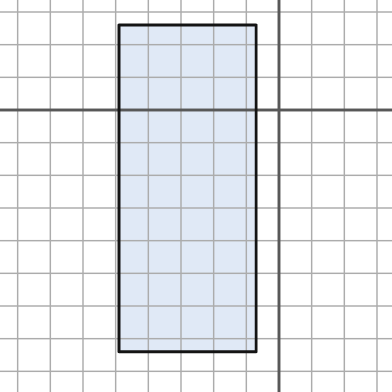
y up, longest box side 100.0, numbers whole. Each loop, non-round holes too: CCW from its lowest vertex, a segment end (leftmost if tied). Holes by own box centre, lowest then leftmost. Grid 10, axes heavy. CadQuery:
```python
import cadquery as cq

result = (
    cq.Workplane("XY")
    .moveTo(-49.0, -74.0)
    .lineTo(-7.0, -74.0)
    .lineTo(-7.0, 26.0)
    .lineTo(-49.0, 26.0)
    .close()
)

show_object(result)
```